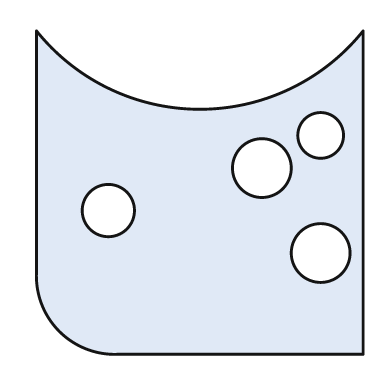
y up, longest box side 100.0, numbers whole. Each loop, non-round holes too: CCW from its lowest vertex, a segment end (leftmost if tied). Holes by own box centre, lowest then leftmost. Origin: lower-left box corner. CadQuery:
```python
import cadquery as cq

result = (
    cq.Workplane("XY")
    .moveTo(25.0, 0.0)
    .lineTo(100.0, 0.0)
    .lineTo(100.0, 99.0)
    .threePointArc((50.0, 75.0), (0.0, 99.0))
    .lineTo(0.0, 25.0)
    .threePointArc((7.0, 7.0), (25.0, 0.0))
    .close()
    .moveTo(87.0, 31.0)
    .circle(9.0)
    .moveTo(22.0, 44.0)
    .circle(8.0)
    .moveTo(69.0, 57.0)
    .circle(9.0)
    .moveTo(87.0, 67.0)
    .circle(7.0)
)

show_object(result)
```